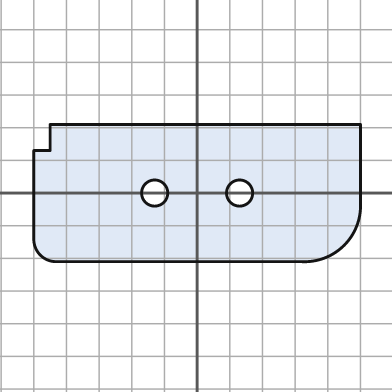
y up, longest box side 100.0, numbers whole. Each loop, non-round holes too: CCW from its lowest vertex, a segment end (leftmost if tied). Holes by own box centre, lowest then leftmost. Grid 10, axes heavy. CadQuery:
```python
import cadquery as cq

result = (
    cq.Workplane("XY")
    .moveTo(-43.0, -21.0)
    .lineTo(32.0, -21.0)
    .threePointArc((45.0, -16.0), (50.0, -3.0))
    .lineTo(50.0, 21.0)
    .lineTo(-45.0, 21.0)
    .lineTo(-45.0, 13.0)
    .lineTo(-50.0, 13.0)
    .lineTo(-50.0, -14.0)
    .threePointArc((-48.0, -19.0), (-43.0, -21.0))
    .close()
    .moveTo(-13.0, 0.0)
    .circle(4.0)
    .moveTo(13.0, 0.0)
    .circle(4.0)
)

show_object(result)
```